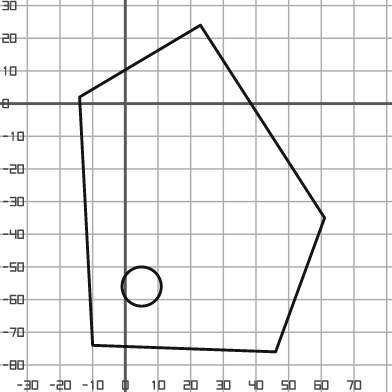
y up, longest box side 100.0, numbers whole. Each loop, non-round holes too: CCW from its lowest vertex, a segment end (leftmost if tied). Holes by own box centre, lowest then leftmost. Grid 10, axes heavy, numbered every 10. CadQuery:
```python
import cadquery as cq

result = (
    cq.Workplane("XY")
    .moveTo(46.0, -76.0)
    .lineTo(61.0, -35.0)
    .lineTo(23.0, 24.0)
    .lineTo(-14.0, 2.0)
    .lineTo(-10.0, -74.0)
    .close()
    .moveTo(5.0, -56.0)
    .circle(6.0)
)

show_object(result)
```